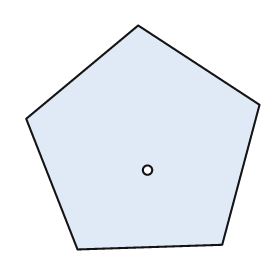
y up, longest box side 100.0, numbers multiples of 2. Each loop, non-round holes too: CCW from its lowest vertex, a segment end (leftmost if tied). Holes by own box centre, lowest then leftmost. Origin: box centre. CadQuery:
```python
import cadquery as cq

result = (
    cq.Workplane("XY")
    .moveTo(-28.0, -48.0)
    .lineTo(34.0, -46.0)
    .lineTo(50.0, 14.0)
    .lineTo(-2.0, 48.0)
    .lineTo(-50.0, 8.0)
    .close()
    .moveTo(2.0, -14.0)
    .circle(2.0)
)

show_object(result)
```